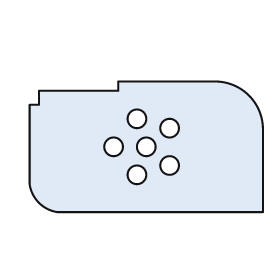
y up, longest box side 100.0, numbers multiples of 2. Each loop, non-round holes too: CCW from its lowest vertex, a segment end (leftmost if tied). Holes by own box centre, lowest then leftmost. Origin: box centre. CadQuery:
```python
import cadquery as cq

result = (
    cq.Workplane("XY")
    .moveTo(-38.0, -28.0)
    .lineTo(50.0, -28.0)
    .lineTo(50.0, 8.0)
    .threePointArc((44.0, 22.0), (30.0, 28.0))
    .lineTo(-12.0, 28.0)
    .lineTo(-12.0, 24.0)
    .lineTo(-46.0, 24.0)
    .lineTo(-46.0, 18.0)
    .lineTo(-50.0, 18.0)
    .lineTo(-50.0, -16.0)
    .threePointArc((-46.0, -24.0), (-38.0, -28.0))
    .close()
    .moveTo(-4.0, -12.0)
    .circle(4.0)
    .moveTo(10.0, -8.0)
    .circle(4.0)
    .moveTo(-14.0, 0.0)
    .circle(4.0)
    .moveTo(0.0, 0.0)
    .circle(4.0)
    .moveTo(10.0, 8.0)
    .circle(4.0)
    .moveTo(-4.0, 12.0)
    .circle(4.0)
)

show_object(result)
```